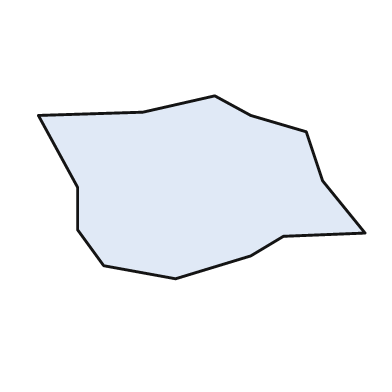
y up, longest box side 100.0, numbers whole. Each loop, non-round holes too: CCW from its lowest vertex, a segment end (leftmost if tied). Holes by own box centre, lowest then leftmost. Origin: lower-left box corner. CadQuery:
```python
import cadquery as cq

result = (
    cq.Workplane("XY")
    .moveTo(42.0, 0.0)
    .lineTo(65.0, 7.0)
    .lineTo(75.0, 13.0)
    .lineTo(100.0, 14.0)
    .lineTo(87.0, 30.0)
    .lineTo(82.0, 45.0)
    .lineTo(65.0, 50.0)
    .lineTo(54.0, 56.0)
    .lineTo(32.0, 51.0)
    .lineTo(0.0, 50.0)
    .lineTo(12.0, 28.0)
    .lineTo(12.0, 15.0)
    .lineTo(20.0, 4.0)
    .close()
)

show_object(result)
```